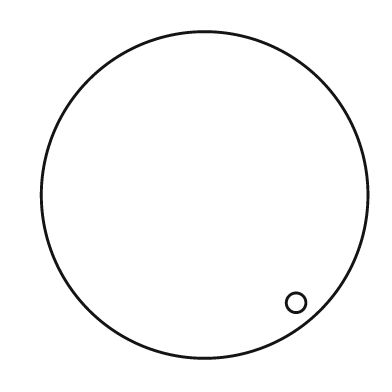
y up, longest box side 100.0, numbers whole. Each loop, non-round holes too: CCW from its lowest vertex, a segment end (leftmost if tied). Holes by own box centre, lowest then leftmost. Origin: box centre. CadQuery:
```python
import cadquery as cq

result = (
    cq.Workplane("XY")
    .moveTo(0.0, 0.0)
    .circle(50.0)
    .moveTo(28.0, -33.0)
    .circle(3.0)
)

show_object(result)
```